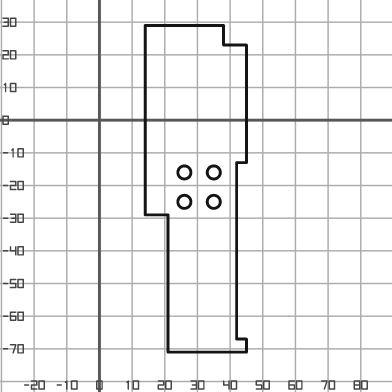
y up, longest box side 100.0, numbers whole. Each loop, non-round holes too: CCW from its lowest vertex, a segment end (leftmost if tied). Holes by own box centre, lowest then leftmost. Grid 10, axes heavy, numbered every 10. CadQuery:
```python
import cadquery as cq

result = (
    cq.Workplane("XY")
    .moveTo(21.0, -71.0)
    .lineTo(45.0, -71.0)
    .lineTo(45.0, -67.0)
    .lineTo(42.0, -67.0)
    .lineTo(42.0, -13.0)
    .lineTo(45.0, -13.0)
    .lineTo(45.0, 23.0)
    .lineTo(38.0, 23.0)
    .lineTo(38.0, 29.0)
    .lineTo(14.0, 29.0)
    .lineTo(14.0, -29.0)
    .lineTo(21.0, -29.0)
    .close()
    .moveTo(26.0, -25.0)
    .circle(2.0)
    .moveTo(35.0, -25.0)
    .circle(2.0)
    .moveTo(26.0, -16.0)
    .circle(2.0)
    .moveTo(35.0, -16.0)
    .circle(2.0)
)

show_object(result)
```